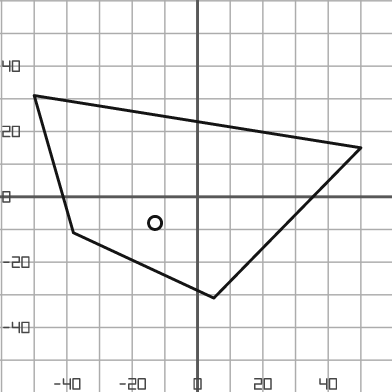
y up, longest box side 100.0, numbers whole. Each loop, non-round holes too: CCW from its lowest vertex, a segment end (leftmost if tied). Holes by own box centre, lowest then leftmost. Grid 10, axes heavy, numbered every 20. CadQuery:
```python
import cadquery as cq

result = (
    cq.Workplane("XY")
    .moveTo(5.0, -31.0)
    .lineTo(50.0, 15.0)
    .lineTo(-50.0, 31.0)
    .lineTo(-38.0, -11.0)
    .close()
    .moveTo(-13.0, -8.0)
    .circle(2.0)
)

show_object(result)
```